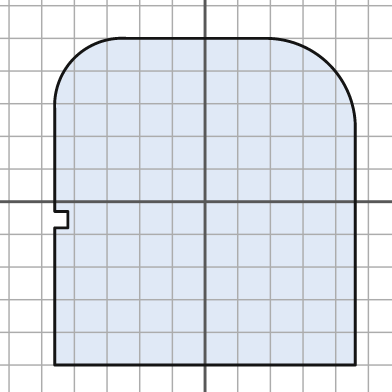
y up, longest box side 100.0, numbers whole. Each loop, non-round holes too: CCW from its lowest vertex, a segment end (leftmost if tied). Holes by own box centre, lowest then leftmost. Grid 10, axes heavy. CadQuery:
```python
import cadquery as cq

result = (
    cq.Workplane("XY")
    .moveTo(-46.0, -50.0)
    .lineTo(46.0, -50.0)
    .lineTo(46.0, 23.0)
    .threePointArc((38.0, 42.0), (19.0, 50.0))
    .lineTo(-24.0, 50.0)
    .threePointArc((-40.0, 44.0), (-46.0, 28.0))
    .lineTo(-46.0, -3.0)
    .lineTo(-42.0, -3.0)
    .lineTo(-42.0, -8.0)
    .lineTo(-46.0, -8.0)
    .close()
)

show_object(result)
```